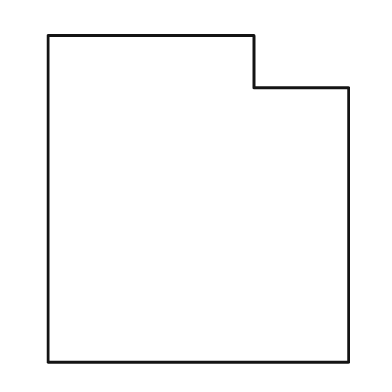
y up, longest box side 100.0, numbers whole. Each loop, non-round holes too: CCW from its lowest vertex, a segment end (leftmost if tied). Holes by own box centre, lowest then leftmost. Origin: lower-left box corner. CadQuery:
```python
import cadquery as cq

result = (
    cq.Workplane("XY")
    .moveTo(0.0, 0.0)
    .lineTo(92.0, 0.0)
    .lineTo(92.0, 84.0)
    .lineTo(63.0, 84.0)
    .lineTo(63.0, 100.0)
    .lineTo(0.0, 100.0)
    .close()
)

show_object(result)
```